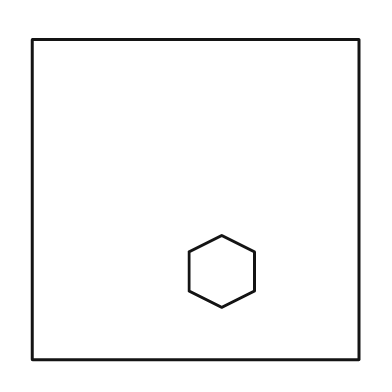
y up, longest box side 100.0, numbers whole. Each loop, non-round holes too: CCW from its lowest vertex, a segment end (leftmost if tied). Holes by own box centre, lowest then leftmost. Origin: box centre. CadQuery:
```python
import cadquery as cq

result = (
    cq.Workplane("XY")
    .moveTo(-50.0, -49.0)
    .lineTo(50.0, -49.0)
    .lineTo(50.0, 49.0)
    .lineTo(-50.0, 49.0)
    .close()
    .moveTo(8.0, -33.0)
    .lineTo(18.0, -28.0)
    .lineTo(18.0, -16.0)
    .lineTo(8.0, -11.0)
    .lineTo(-2.0, -16.0)
    .lineTo(-2.0, -28.0)
    .close()
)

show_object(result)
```